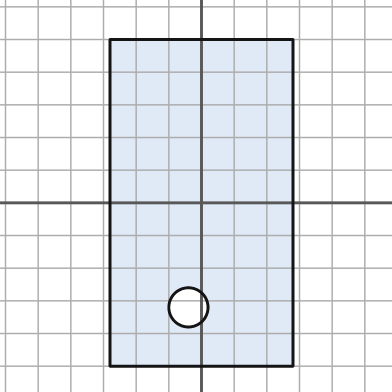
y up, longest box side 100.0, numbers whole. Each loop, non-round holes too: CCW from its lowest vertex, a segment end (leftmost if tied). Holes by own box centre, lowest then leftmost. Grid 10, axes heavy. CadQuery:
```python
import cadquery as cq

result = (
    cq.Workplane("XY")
    .moveTo(-28.0, -50.0)
    .lineTo(28.0, -50.0)
    .lineTo(28.0, 50.0)
    .lineTo(-28.0, 50.0)
    .close()
    .moveTo(-4.0, -32.0)
    .circle(6.0)
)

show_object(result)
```